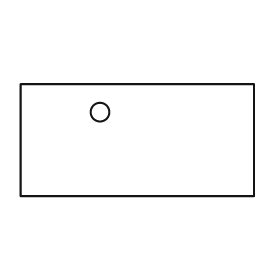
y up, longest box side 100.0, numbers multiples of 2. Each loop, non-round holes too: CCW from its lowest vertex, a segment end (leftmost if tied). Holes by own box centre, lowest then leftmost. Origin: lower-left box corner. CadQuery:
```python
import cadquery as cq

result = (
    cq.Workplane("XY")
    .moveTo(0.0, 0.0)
    .lineTo(100.0, 0.0)
    .lineTo(100.0, 48.0)
    .lineTo(0.0, 48.0)
    .close()
    .moveTo(34.0, 36.0)
    .circle(4.0)
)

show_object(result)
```